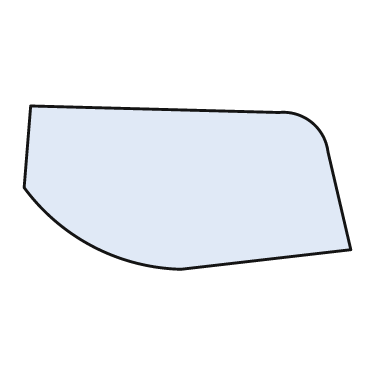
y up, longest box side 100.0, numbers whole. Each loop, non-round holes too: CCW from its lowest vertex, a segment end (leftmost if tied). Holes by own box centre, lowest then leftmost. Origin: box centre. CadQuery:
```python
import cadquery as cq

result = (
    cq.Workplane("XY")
    .moveTo(-2.0, -25.0)
    .lineTo(50.0, -19.0)
    .lineTo(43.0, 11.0)
    .threePointArc((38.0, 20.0), (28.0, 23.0))
    .lineTo(-48.0, 25.0)
    .lineTo(-50.0, 0.0)
    .threePointArc((-29.0, -18.0), (-2.0, -25.0))
    .close()
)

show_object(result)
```